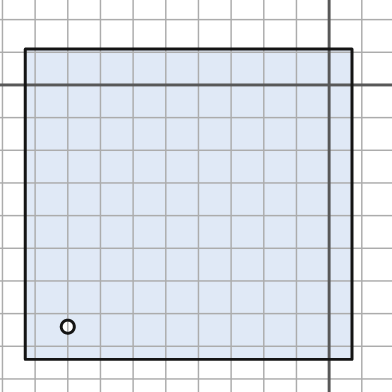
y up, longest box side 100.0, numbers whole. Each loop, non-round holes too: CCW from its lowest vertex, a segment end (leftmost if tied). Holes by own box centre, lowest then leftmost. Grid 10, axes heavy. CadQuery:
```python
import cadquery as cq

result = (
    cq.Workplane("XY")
    .moveTo(-93.0, -84.0)
    .lineTo(7.0, -84.0)
    .lineTo(7.0, 11.0)
    .lineTo(-93.0, 11.0)
    .close()
    .moveTo(-80.0, -74.0)
    .circle(2.0)
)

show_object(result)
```